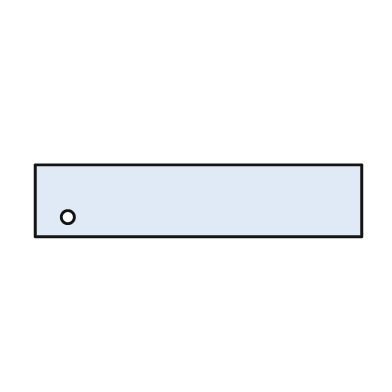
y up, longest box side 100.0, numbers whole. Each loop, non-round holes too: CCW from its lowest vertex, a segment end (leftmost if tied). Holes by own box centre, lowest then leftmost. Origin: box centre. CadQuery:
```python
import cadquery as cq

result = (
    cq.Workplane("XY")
    .moveTo(-50.0, -11.0)
    .lineTo(50.0, -11.0)
    .lineTo(50.0, 11.0)
    .lineTo(-50.0, 11.0)
    .close()
    .moveTo(-40.0, -5.0)
    .circle(2.0)
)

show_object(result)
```